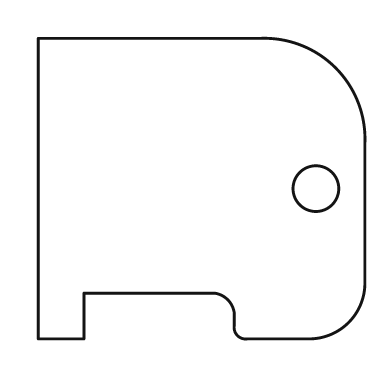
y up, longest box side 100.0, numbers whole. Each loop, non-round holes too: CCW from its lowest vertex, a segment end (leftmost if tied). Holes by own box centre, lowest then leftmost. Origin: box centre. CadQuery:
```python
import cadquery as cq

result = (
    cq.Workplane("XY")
    .moveTo(-50.0, -46.0)
    .lineTo(-36.0, -46.0)
    .lineTo(-36.0, -32.0)
    .lineTo(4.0, -32.0)
    .threePointArc((8.0, -34.0), (10.0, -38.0))
    .lineTo(10.0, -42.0)
    .threePointArc((11.0, -45.0), (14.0, -46.0))
    .lineTo(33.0, -46.0)
    .threePointArc((45.0, -41.0), (50.0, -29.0))
    .lineTo(50.0, 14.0)
    .threePointArc((41.0, 37.0), (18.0, 46.0))
    .lineTo(-50.0, 46.0)
    .close()
    .moveTo(35.0, 0.0)
    .circle(7.0)
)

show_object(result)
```